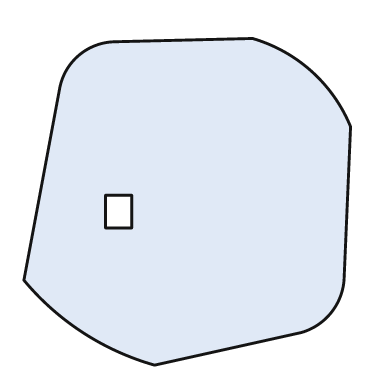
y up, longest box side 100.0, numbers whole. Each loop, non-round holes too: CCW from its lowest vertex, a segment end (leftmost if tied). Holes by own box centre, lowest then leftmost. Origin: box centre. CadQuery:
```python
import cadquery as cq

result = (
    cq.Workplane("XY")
    .moveTo(-10.0, -50.0)
    .lineTo(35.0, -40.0)
    .threePointArc((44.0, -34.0), (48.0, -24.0))
    .lineTo(50.0, 23.0)
    .threePointArc((38.0, 40.0), (20.0, 50.0))
    .lineTo(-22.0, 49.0)
    .threePointArc((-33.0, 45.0), (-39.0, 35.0))
    .lineTo(-50.0, -24.0)
    .threePointArc((-32.0, -40.0), (-10.0, -50.0))
    .close()
    .moveTo(-25.0, -8.0)
    .lineTo(-17.0, -8.0)
    .lineTo(-17.0, 2.0)
    .lineTo(-25.0, 2.0)
    .close()
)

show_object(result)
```